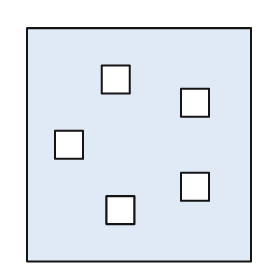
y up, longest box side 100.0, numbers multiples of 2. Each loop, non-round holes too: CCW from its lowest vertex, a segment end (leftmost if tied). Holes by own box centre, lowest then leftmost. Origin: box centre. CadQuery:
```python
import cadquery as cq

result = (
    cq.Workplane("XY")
    .moveTo(-48.0, -50.0)
    .lineTo(48.0, -50.0)
    .lineTo(48.0, 50.0)
    .lineTo(-48.0, 50.0)
    .close()
    .moveTo(-14.0, -34.0)
    .lineTo(-2.0, -34.0)
    .lineTo(-2.0, -22.0)
    .lineTo(-14.0, -22.0)
    .close()
    .moveTo(18.0, -24.0)
    .lineTo(30.0, -24.0)
    .lineTo(30.0, -12.0)
    .lineTo(18.0, -12.0)
    .close()
    .moveTo(-36.0, -6.0)
    .lineTo(-24.0, -6.0)
    .lineTo(-24.0, 6.0)
    .lineTo(-36.0, 6.0)
    .close()
    .moveTo(18.0, 12.0)
    .lineTo(30.0, 12.0)
    .lineTo(30.0, 24.0)
    .lineTo(18.0, 24.0)
    .close()
    .moveTo(-16.0, 22.0)
    .lineTo(-4.0, 22.0)
    .lineTo(-4.0, 34.0)
    .lineTo(-16.0, 34.0)
    .close()
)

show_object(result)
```